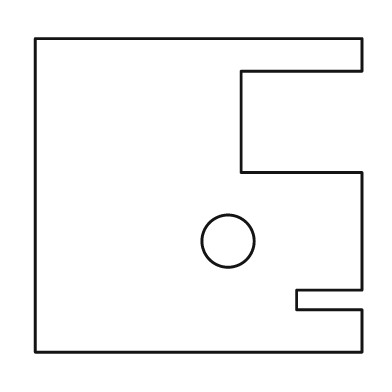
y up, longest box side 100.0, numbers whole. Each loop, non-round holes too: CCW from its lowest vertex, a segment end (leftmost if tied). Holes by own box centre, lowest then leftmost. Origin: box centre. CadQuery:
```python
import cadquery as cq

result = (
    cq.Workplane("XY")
    .moveTo(-50.0, -48.0)
    .lineTo(50.0, -48.0)
    .lineTo(50.0, -35.0)
    .lineTo(30.0, -35.0)
    .lineTo(30.0, -29.0)
    .lineTo(50.0, -29.0)
    .lineTo(50.0, 7.0)
    .lineTo(13.0, 7.0)
    .lineTo(13.0, 38.0)
    .lineTo(50.0, 38.0)
    .lineTo(50.0, 48.0)
    .lineTo(-50.0, 48.0)
    .close()
    .moveTo(9.0, -14.0)
    .circle(8.0)
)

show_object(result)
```